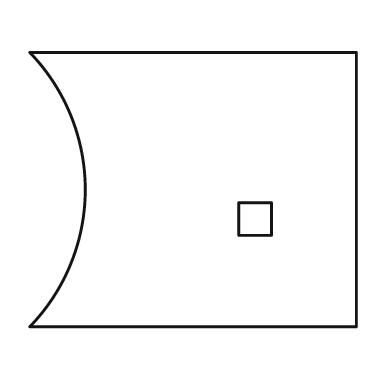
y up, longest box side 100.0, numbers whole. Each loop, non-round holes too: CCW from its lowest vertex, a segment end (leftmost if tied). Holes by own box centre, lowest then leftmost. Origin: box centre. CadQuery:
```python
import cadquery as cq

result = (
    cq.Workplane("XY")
    .moveTo(-50.0, -42.0)
    .lineTo(50.0, -42.0)
    .lineTo(50.0, 42.0)
    .lineTo(-50.0, 42.0)
    .threePointArc((-33.0, 0.0), (-50.0, -42.0))
    .close()
    .moveTo(14.0, -14.0)
    .lineTo(24.0, -14.0)
    .lineTo(24.0, -4.0)
    .lineTo(14.0, -4.0)
    .close()
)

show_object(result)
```